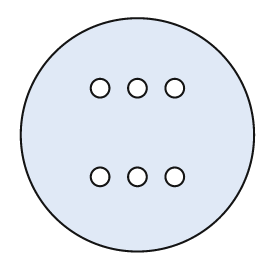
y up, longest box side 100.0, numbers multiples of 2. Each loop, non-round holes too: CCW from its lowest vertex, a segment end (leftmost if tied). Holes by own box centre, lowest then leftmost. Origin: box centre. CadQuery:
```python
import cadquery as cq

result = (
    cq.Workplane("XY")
    .moveTo(0.0, 0.0)
    .circle(50.0)
    .moveTo(-16.0, -18.0)
    .circle(4.0)
    .moveTo(0.0, -18.0)
    .circle(4.0)
    .moveTo(16.0, -18.0)
    .circle(4.0)
    .moveTo(-16.0, 20.0)
    .circle(4.0)
    .moveTo(0.0, 20.0)
    .circle(4.0)
    .moveTo(16.0, 20.0)
    .circle(4.0)
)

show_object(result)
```